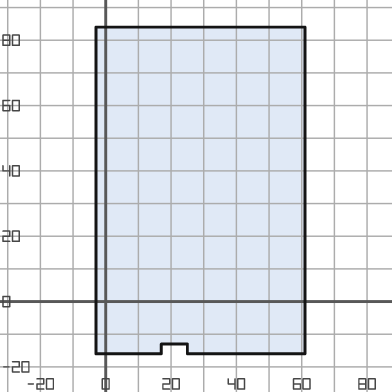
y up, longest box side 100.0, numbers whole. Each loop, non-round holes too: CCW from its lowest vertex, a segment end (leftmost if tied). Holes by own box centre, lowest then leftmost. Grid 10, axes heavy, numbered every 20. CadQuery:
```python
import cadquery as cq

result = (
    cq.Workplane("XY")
    .moveTo(-3.0, -16.0)
    .lineTo(17.0, -16.0)
    .lineTo(17.0, -13.0)
    .lineTo(25.0, -13.0)
    .lineTo(25.0, -16.0)
    .lineTo(61.0, -16.0)
    .lineTo(61.0, 84.0)
    .lineTo(-3.0, 84.0)
    .close()
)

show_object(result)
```